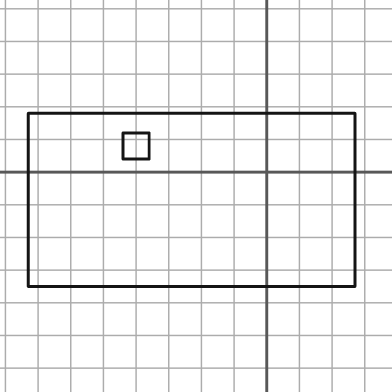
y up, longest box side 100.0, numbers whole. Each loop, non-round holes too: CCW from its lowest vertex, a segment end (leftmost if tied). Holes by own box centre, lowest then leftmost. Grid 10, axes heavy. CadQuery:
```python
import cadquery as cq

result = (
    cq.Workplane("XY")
    .moveTo(-73.0, -35.0)
    .lineTo(27.0, -35.0)
    .lineTo(27.0, 18.0)
    .lineTo(-73.0, 18.0)
    .close()
    .moveTo(-44.0, 4.0)
    .lineTo(-36.0, 4.0)
    .lineTo(-36.0, 12.0)
    .lineTo(-44.0, 12.0)
    .close()
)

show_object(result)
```